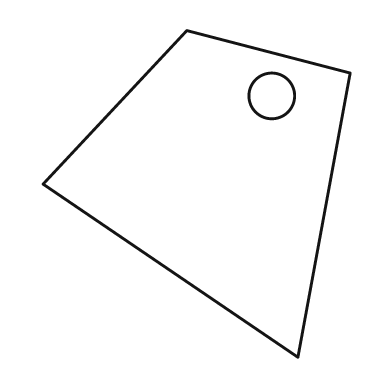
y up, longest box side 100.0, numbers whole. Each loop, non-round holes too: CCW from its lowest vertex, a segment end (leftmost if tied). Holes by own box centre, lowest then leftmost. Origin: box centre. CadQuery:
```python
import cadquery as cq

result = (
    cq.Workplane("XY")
    .moveTo(31.0, -50.0)
    .lineTo(47.0, 37.0)
    .lineTo(-3.0, 50.0)
    .lineTo(-47.0, 3.0)
    .close()
    .moveTo(23.0, 30.0)
    .circle(7.0)
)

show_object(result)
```